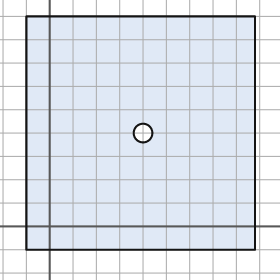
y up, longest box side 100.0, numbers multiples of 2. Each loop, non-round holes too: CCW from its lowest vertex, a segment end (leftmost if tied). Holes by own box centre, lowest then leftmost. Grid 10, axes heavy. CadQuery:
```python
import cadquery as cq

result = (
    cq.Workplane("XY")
    .moveTo(-10.0, -10.0)
    .lineTo(88.0, -10.0)
    .lineTo(88.0, 90.0)
    .lineTo(-10.0, 90.0)
    .close()
    .moveTo(40.0, 40.0)
    .circle(4.0)
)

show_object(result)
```